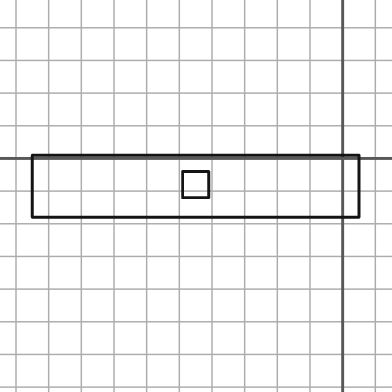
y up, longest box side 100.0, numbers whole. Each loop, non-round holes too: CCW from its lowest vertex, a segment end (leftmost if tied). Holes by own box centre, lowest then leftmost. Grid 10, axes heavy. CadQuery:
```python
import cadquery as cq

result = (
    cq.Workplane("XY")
    .moveTo(-95.0, -18.0)
    .lineTo(5.0, -18.0)
    .lineTo(5.0, 1.0)
    .lineTo(-95.0, 1.0)
    .close()
    .moveTo(-49.0, -12.0)
    .lineTo(-41.0, -12.0)
    .lineTo(-41.0, -4.0)
    .lineTo(-49.0, -4.0)
    .close()
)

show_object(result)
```